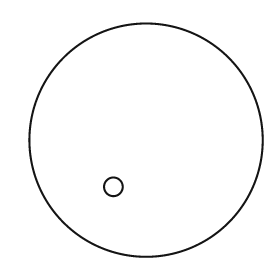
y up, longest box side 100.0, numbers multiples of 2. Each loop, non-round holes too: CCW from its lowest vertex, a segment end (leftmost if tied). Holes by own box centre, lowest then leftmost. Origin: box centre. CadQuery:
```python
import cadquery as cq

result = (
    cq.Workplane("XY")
    .moveTo(0.0, 0.0)
    .circle(50.0)
    .moveTo(-14.0, -20.0)
    .circle(4.0)
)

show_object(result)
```